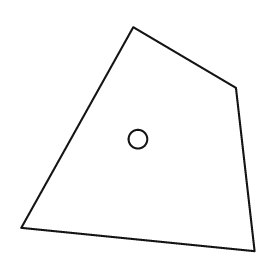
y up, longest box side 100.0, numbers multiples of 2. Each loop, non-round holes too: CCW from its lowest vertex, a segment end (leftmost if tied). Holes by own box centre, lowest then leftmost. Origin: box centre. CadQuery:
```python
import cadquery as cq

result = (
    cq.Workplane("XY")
    .moveTo(50.0, -48.0)
    .lineTo(42.0, 22.0)
    .lineTo(-2.0, 48.0)
    .lineTo(-50.0, -38.0)
    .close()
    .moveTo(0.0, 0.0)
    .circle(4.0)
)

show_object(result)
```